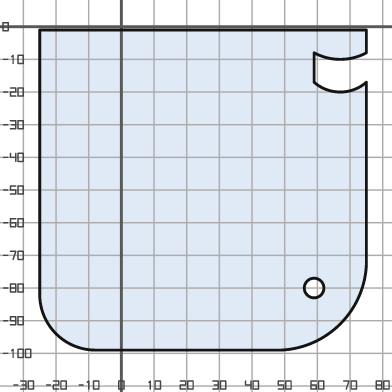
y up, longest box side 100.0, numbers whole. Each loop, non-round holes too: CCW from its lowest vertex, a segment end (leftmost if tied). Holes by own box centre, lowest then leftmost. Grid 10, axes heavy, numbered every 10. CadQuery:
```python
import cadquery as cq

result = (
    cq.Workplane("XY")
    .moveTo(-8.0, -99.0)
    .lineTo(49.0, -99.0)
    .threePointArc((67.0, -91.0), (75.0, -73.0))
    .lineTo(75.0, -17.0)
    .threePointArc((67.0, -20.0), (59.0, -17.0))
    .lineTo(59.0, -8.0)
    .threePointArc((67.0, -10.0), (75.0, -8.0))
    .lineTo(75.0, -1.0)
    .lineTo(-25.0, -1.0)
    .lineTo(-25.0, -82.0)
    .threePointArc((-20.0, -94.0), (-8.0, -99.0))
    .close()
    .moveTo(59.0, -80.0)
    .circle(3.0)
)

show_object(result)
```